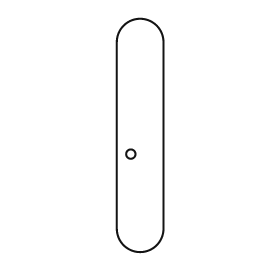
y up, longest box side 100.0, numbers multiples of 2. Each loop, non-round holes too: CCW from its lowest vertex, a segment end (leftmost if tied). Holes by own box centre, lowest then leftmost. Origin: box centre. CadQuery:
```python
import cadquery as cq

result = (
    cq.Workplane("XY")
    .moveTo(-10.0, -40.0)
    .threePointArc((0.0, -50.0), (10.0, -40.0))
    .lineTo(10.0, 40.0)
    .threePointArc((0.0, 50.0), (-10.0, 40.0))
    .close()
    .moveTo(-4.0, -8.0)
    .circle(2.0)
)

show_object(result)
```